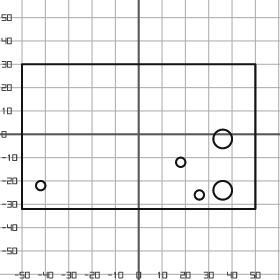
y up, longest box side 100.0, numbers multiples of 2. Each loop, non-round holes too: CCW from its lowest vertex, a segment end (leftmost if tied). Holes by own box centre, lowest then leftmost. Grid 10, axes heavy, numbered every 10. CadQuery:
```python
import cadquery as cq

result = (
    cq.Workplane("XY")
    .moveTo(-50.0, -32.0)
    .lineTo(50.0, -32.0)
    .lineTo(50.0, 30.0)
    .lineTo(-50.0, 30.0)
    .close()
    .moveTo(26.0, -26.0)
    .circle(2.0)
    .moveTo(36.0, -24.0)
    .circle(4.0)
    .moveTo(-42.0, -22.0)
    .circle(2.0)
    .moveTo(18.0, -12.0)
    .circle(2.0)
    .moveTo(36.0, -2.0)
    .circle(4.0)
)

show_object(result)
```